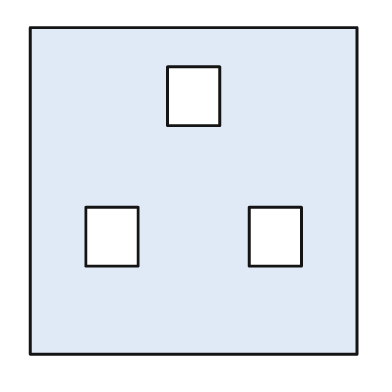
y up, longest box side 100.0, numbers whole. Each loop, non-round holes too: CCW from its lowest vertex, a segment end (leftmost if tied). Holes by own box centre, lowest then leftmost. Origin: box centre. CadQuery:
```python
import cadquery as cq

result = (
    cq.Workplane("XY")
    .moveTo(-50.0, -50.0)
    .lineTo(50.0, -50.0)
    .lineTo(50.0, 50.0)
    .lineTo(-50.0, 50.0)
    .close()
    .moveTo(-33.0, -23.0)
    .lineTo(-17.0, -23.0)
    .lineTo(-17.0, -5.0)
    .lineTo(-33.0, -5.0)
    .close()
    .moveTo(17.0, -23.0)
    .lineTo(33.0, -23.0)
    .lineTo(33.0, -5.0)
    .lineTo(17.0, -5.0)
    .close()
    .moveTo(-8.0, 20.0)
    .lineTo(8.0, 20.0)
    .lineTo(8.0, 38.0)
    .lineTo(-8.0, 38.0)
    .close()
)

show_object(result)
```